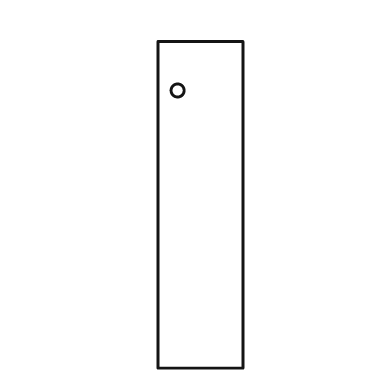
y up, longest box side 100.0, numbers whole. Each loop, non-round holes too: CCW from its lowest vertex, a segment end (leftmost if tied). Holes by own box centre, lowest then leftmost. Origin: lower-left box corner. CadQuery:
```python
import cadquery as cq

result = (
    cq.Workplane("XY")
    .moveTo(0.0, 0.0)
    .lineTo(26.0, 0.0)
    .lineTo(26.0, 100.0)
    .lineTo(0.0, 100.0)
    .close()
    .moveTo(6.0, 85.0)
    .circle(2.0)
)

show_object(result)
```